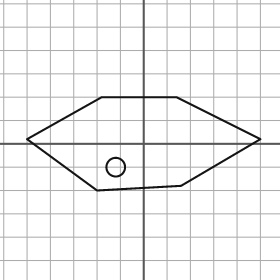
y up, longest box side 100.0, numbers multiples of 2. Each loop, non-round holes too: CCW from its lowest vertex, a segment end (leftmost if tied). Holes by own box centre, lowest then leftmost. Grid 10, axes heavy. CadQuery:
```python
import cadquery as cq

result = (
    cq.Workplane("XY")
    .moveTo(-20.0, -20.0)
    .lineTo(16.0, -18.0)
    .lineTo(50.0, 2.0)
    .lineTo(14.0, 20.0)
    .lineTo(-18.0, 20.0)
    .lineTo(-50.0, 2.0)
    .close()
    .moveTo(-12.0, -10.0)
    .circle(4.0)
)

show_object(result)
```